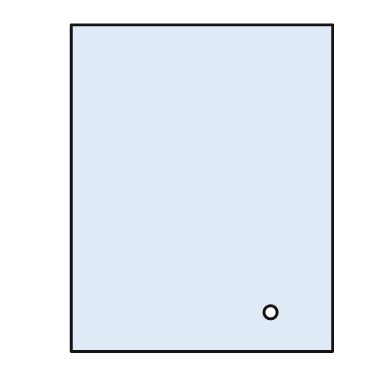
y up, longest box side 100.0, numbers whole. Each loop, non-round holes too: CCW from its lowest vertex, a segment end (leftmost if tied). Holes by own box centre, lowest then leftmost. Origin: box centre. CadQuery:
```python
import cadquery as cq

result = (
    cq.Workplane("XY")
    .moveTo(-40.0, -50.0)
    .lineTo(40.0, -50.0)
    .lineTo(40.0, 50.0)
    .lineTo(-40.0, 50.0)
    .close()
    .moveTo(21.0, -38.0)
    .circle(2.0)
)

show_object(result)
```